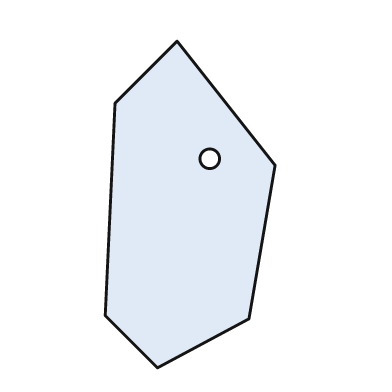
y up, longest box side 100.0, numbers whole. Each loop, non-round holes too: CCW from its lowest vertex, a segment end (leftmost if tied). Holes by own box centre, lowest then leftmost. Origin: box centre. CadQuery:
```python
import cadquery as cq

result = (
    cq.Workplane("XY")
    .moveTo(-10.0, -50.0)
    .lineTo(18.0, -35.0)
    .lineTo(26.0, 12.0)
    .lineTo(-4.0, 50.0)
    .lineTo(-23.0, 31.0)
    .lineTo(-26.0, -34.0)
    .close()
    .moveTo(6.0, 14.0)
    .circle(3.0)
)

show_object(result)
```